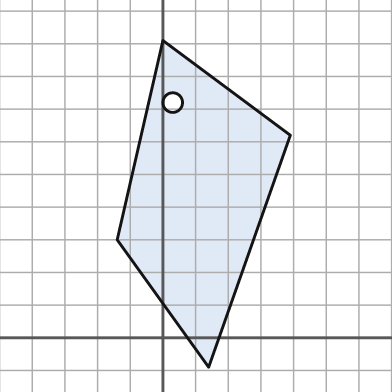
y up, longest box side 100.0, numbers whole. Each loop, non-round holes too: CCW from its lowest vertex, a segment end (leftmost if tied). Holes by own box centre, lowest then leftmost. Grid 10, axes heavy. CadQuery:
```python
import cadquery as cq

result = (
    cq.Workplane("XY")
    .moveTo(14.0, -9.0)
    .lineTo(39.0, 62.0)
    .lineTo(0.0, 91.0)
    .lineTo(-14.0, 30.0)
    .close()
    .moveTo(3.0, 72.0)
    .circle(3.0)
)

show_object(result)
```